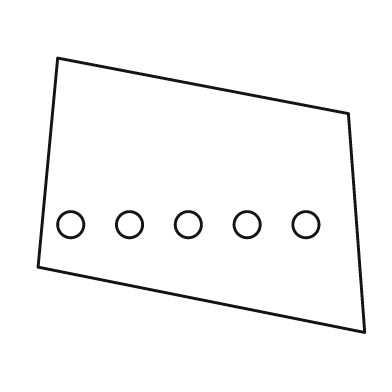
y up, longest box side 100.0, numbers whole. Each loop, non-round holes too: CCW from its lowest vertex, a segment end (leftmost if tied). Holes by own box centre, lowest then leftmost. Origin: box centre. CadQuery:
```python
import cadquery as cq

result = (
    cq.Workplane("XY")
    .moveTo(50.0, -42.0)
    .lineTo(45.0, 25.0)
    .lineTo(-44.0, 42.0)
    .lineTo(-50.0, -22.0)
    .close()
    .moveTo(-40.0, -9.0)
    .circle(4.0)
    .moveTo(-22.0, -9.0)
    .circle(4.0)
    .moveTo(-4.0, -9.0)
    .circle(4.0)
    .moveTo(14.0, -9.0)
    .circle(4.0)
    .moveTo(32.0, -9.0)
    .circle(4.0)
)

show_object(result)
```